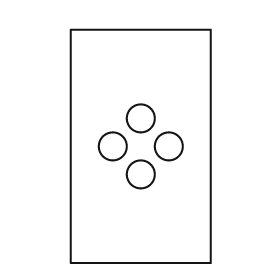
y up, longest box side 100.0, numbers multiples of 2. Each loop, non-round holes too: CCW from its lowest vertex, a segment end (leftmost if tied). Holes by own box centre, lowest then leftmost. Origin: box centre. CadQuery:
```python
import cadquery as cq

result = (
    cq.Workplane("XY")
    .moveTo(-30.0, -50.0)
    .lineTo(30.0, -50.0)
    .lineTo(30.0, 50.0)
    .lineTo(-30.0, 50.0)
    .close()
    .moveTo(0.0, -12.0)
    .circle(6.0)
    .moveTo(-12.0, 0.0)
    .circle(6.0)
    .moveTo(12.0, 0.0)
    .circle(6.0)
    .moveTo(0.0, 12.0)
    .circle(6.0)
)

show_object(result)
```